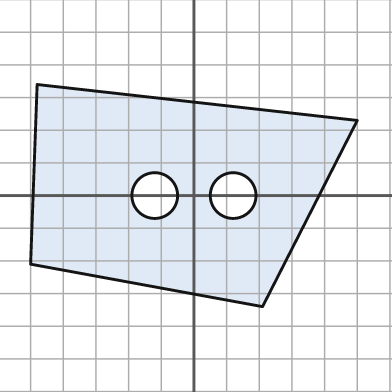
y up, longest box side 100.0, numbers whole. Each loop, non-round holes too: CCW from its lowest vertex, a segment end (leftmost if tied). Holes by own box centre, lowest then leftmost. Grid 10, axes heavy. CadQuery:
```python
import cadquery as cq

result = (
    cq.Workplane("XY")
    .moveTo(21.0, -34.0)
    .lineTo(50.0, 23.0)
    .lineTo(-48.0, 34.0)
    .lineTo(-50.0, -21.0)
    .close()
    .moveTo(-12.0, 0.0)
    .circle(7.0)
    .moveTo(12.0, 0.0)
    .circle(7.0)
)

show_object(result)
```